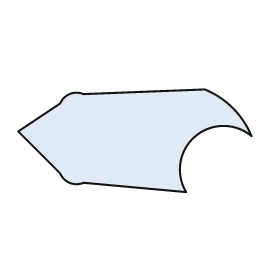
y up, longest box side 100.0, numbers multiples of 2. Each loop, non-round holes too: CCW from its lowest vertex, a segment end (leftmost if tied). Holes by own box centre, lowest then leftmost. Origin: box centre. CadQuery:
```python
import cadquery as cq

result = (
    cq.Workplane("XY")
    .moveTo(22.0, -22.0)
    .threePointArc((26.0, 2.0), (50.0, 2.0))
    .threePointArc((42.0, 14.0), (30.0, 22.0))
    .lineTo(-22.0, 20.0)
    .threePointArc((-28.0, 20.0), (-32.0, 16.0))
    .lineTo(-50.0, 4.0)
    .lineTo(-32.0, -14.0)
    .threePointArc((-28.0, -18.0), (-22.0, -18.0))
    .close()
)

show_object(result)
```